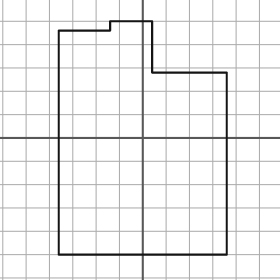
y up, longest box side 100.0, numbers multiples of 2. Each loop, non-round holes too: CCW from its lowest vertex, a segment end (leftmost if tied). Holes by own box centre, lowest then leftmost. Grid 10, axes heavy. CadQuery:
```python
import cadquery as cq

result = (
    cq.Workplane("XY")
    .moveTo(-36.0, -50.0)
    .lineTo(36.0, -50.0)
    .lineTo(36.0, 28.0)
    .lineTo(4.0, 28.0)
    .lineTo(4.0, 50.0)
    .lineTo(-14.0, 50.0)
    .lineTo(-14.0, 46.0)
    .lineTo(-36.0, 46.0)
    .close()
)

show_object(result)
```